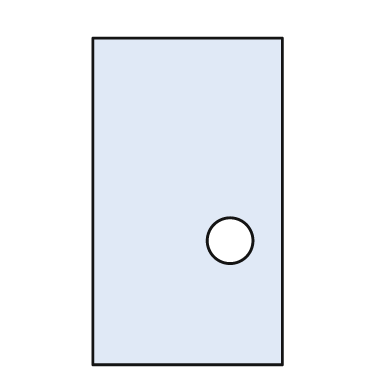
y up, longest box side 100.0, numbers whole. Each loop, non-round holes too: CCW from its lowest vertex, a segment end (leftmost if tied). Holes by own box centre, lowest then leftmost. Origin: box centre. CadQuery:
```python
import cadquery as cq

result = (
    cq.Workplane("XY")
    .moveTo(-29.0, -50.0)
    .lineTo(29.0, -50.0)
    .lineTo(29.0, 50.0)
    .lineTo(-29.0, 50.0)
    .close()
    .moveTo(13.0, -12.0)
    .circle(7.0)
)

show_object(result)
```